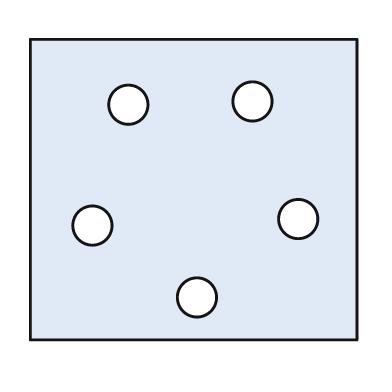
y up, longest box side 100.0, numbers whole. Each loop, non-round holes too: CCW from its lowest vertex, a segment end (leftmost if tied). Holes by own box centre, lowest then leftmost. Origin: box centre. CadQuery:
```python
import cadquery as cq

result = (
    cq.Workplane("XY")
    .moveTo(-50.0, -46.0)
    .lineTo(50.0, -46.0)
    .lineTo(50.0, 46.0)
    .lineTo(-50.0, 46.0)
    .close()
    .moveTo(1.0, -33.0)
    .circle(6.0)
    .moveTo(-31.0, -11.0)
    .circle(6.0)
    .moveTo(32.0, -9.0)
    .circle(6.0)
    .moveTo(-20.0, 26.0)
    .circle(6.0)
    .moveTo(18.0, 27.0)
    .circle(6.0)
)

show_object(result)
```